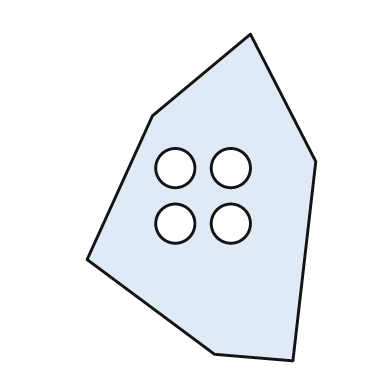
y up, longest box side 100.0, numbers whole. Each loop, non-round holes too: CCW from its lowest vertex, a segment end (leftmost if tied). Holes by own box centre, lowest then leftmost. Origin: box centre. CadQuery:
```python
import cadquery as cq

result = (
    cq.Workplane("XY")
    .moveTo(28.0, -50.0)
    .lineTo(35.0, 11.0)
    .lineTo(15.0, 50.0)
    .lineTo(-15.0, 25.0)
    .lineTo(-35.0, -19.0)
    .lineTo(4.0, -48.0)
    .close()
    .moveTo(-8.0, -8.0)
    .circle(6.0)
    .moveTo(9.0, -8.0)
    .circle(6.0)
    .moveTo(-8.0, 9.0)
    .circle(6.0)
    .moveTo(9.0, 9.0)
    .circle(6.0)
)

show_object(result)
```